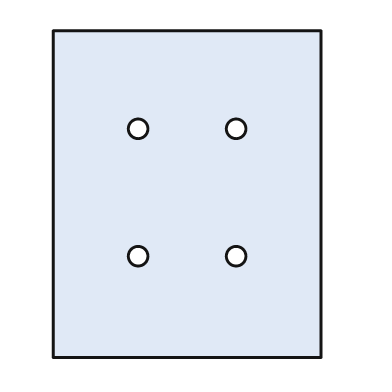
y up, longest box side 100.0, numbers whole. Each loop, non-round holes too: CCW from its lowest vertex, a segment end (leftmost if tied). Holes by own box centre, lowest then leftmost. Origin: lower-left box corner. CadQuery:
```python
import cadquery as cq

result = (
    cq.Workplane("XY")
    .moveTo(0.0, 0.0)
    .lineTo(82.0, 0.0)
    .lineTo(82.0, 100.0)
    .lineTo(0.0, 100.0)
    .close()
    .moveTo(26.0, 31.0)
    .circle(3.0)
    .moveTo(56.0, 31.0)
    .circle(3.0)
    .moveTo(26.0, 70.0)
    .circle(3.0)
    .moveTo(56.0, 70.0)
    .circle(3.0)
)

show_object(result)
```